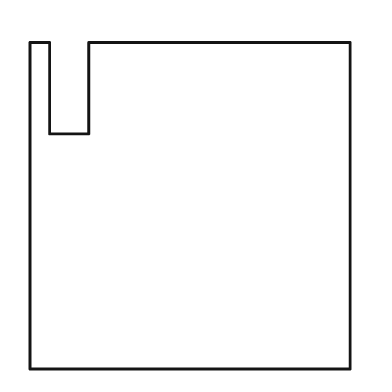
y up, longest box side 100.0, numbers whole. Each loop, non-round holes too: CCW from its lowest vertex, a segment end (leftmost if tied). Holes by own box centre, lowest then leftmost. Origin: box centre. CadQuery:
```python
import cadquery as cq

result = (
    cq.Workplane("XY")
    .moveTo(-49.0, -50.0)
    .lineTo(49.0, -50.0)
    .lineTo(49.0, 50.0)
    .lineTo(-31.0, 50.0)
    .lineTo(-31.0, 22.0)
    .lineTo(-43.0, 22.0)
    .lineTo(-43.0, 50.0)
    .lineTo(-49.0, 50.0)
    .close()
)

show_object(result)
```